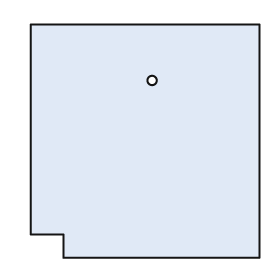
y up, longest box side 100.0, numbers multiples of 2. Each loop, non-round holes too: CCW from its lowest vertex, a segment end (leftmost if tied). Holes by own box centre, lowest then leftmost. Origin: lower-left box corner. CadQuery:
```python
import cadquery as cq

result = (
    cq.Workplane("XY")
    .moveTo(14.0, 0.0)
    .lineTo(98.0, 0.0)
    .lineTo(98.0, 100.0)
    .lineTo(0.0, 100.0)
    .lineTo(0.0, 10.0)
    .lineTo(14.0, 10.0)
    .close()
    .moveTo(52.0, 76.0)
    .circle(2.0)
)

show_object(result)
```